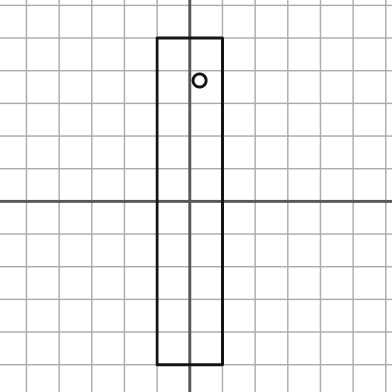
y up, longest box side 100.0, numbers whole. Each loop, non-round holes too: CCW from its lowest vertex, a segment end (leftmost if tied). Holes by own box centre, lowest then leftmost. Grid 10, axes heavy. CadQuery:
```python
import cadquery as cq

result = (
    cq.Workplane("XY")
    .moveTo(-10.0, -50.0)
    .lineTo(10.0, -50.0)
    .lineTo(10.0, 50.0)
    .lineTo(-10.0, 50.0)
    .close()
    .moveTo(3.0, 37.0)
    .circle(2.0)
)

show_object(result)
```